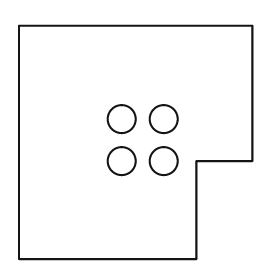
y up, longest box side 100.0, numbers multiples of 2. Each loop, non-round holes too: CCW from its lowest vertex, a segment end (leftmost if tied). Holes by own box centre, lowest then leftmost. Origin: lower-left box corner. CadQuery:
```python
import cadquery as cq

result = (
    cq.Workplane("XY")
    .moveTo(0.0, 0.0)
    .lineTo(76.0, 0.0)
    .lineTo(76.0, 42.0)
    .lineTo(100.0, 42.0)
    .lineTo(100.0, 100.0)
    .lineTo(0.0, 100.0)
    .close()
    .moveTo(44.0, 42.0)
    .circle(6.0)
    .moveTo(62.0, 42.0)
    .circle(6.0)
    .moveTo(44.0, 60.0)
    .circle(6.0)
    .moveTo(62.0, 60.0)
    .circle(6.0)
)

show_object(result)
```